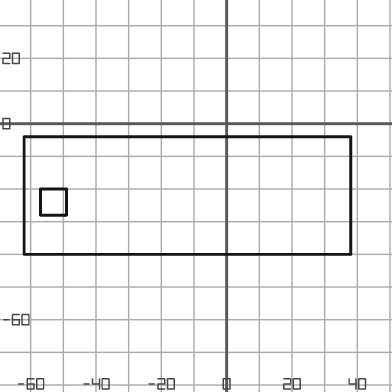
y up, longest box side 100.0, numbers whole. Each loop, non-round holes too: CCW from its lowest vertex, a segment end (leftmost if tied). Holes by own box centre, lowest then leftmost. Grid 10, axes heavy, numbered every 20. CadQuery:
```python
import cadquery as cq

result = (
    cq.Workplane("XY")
    .moveTo(-62.0, -40.0)
    .lineTo(38.0, -40.0)
    .lineTo(38.0, -4.0)
    .lineTo(-62.0, -4.0)
    .close()
    .moveTo(-57.0, -28.0)
    .lineTo(-49.0, -28.0)
    .lineTo(-49.0, -20.0)
    .lineTo(-57.0, -20.0)
    .close()
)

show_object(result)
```